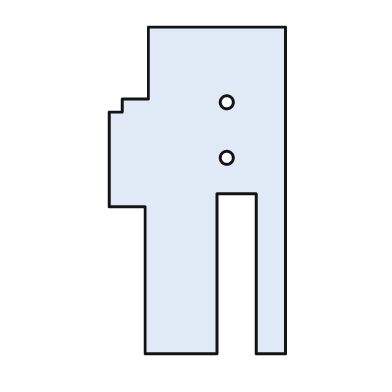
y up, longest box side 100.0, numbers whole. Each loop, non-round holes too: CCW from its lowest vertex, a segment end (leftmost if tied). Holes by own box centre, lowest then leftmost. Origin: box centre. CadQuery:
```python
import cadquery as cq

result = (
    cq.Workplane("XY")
    .moveTo(-16.0, -50.0)
    .lineTo(6.0, -50.0)
    .lineTo(6.0, -1.0)
    .lineTo(18.0, -1.0)
    .lineTo(18.0, -50.0)
    .lineTo(27.0, -50.0)
    .lineTo(27.0, 50.0)
    .lineTo(-15.0, 50.0)
    .lineTo(-15.0, 28.0)
    .lineTo(-23.0, 28.0)
    .lineTo(-23.0, 24.0)
    .lineTo(-27.0, 24.0)
    .lineTo(-27.0, -5.0)
    .lineTo(-16.0, -5.0)
    .close()
    .moveTo(9.0, 10.0)
    .circle(2.0)
    .moveTo(9.0, 27.0)
    .circle(2.0)
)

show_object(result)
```